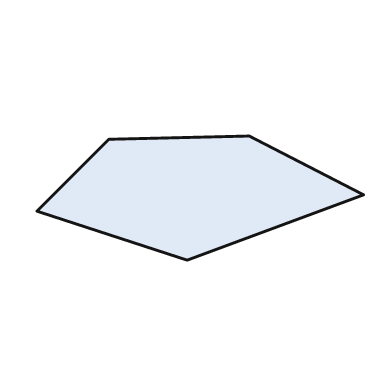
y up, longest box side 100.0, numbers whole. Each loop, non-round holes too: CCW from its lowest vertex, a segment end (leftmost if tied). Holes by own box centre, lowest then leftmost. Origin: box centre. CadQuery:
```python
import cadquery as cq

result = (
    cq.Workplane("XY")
    .moveTo(-4.0, -19.0)
    .lineTo(50.0, 1.0)
    .lineTo(15.0, 19.0)
    .lineTo(-28.0, 18.0)
    .lineTo(-50.0, -4.0)
    .close()
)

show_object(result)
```